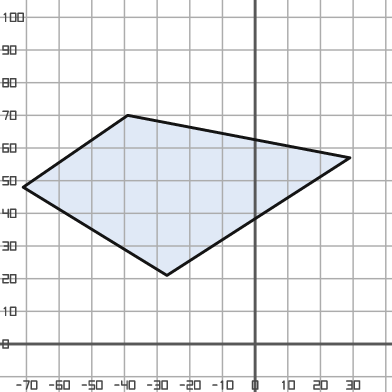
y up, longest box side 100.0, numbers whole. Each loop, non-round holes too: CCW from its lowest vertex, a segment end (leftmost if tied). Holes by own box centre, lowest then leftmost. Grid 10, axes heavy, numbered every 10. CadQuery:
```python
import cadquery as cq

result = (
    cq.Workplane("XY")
    .moveTo(-27.0, 21.0)
    .lineTo(29.0, 57.0)
    .lineTo(-39.0, 70.0)
    .lineTo(-71.0, 48.0)
    .close()
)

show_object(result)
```